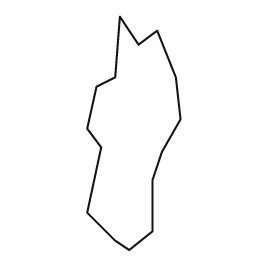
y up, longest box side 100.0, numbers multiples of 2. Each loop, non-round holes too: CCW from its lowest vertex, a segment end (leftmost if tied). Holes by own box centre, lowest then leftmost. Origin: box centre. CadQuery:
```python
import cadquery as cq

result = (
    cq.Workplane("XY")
    .moveTo(-2.0, -50.0)
    .lineTo(8.0, -42.0)
    .lineTo(8.0, -20.0)
    .lineTo(12.0, -8.0)
    .lineTo(20.0, 6.0)
    .lineTo(18.0, 24.0)
    .lineTo(10.0, 44.0)
    .lineTo(2.0, 38.0)
    .lineTo(-6.0, 50.0)
    .lineTo(-8.0, 24.0)
    .lineTo(-16.0, 20.0)
    .lineTo(-20.0, 2.0)
    .lineTo(-14.0, -6.0)
    .lineTo(-20.0, -34.0)
    .lineTo(-8.0, -46.0)
    .close()
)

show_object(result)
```